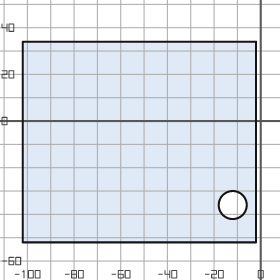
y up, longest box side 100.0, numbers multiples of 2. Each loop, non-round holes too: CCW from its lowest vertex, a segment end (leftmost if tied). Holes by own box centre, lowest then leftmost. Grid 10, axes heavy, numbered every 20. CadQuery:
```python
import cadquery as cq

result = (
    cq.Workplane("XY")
    .moveTo(-102.0, -52.0)
    .lineTo(-2.0, -52.0)
    .lineTo(-2.0, 34.0)
    .lineTo(-102.0, 34.0)
    .close()
    .moveTo(-12.0, -36.0)
    .circle(6.0)
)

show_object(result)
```